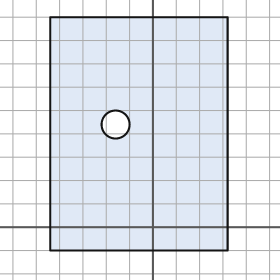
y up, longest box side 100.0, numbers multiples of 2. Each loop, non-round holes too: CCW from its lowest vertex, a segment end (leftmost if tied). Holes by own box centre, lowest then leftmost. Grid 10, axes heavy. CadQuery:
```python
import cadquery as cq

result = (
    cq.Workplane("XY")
    .moveTo(-44.0, -10.0)
    .lineTo(32.0, -10.0)
    .lineTo(32.0, 90.0)
    .lineTo(-44.0, 90.0)
    .close()
    .moveTo(-16.0, 44.0)
    .circle(6.0)
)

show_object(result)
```